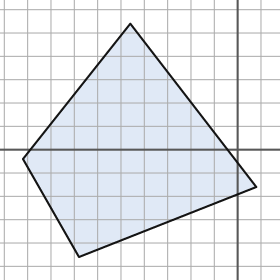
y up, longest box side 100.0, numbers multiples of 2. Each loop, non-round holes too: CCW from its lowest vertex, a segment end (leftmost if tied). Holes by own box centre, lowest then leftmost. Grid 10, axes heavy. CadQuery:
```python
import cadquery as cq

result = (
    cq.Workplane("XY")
    .moveTo(-68.0, -46.0)
    .lineTo(8.0, -16.0)
    .lineTo(-46.0, 54.0)
    .lineTo(-92.0, -4.0)
    .close()
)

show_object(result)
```